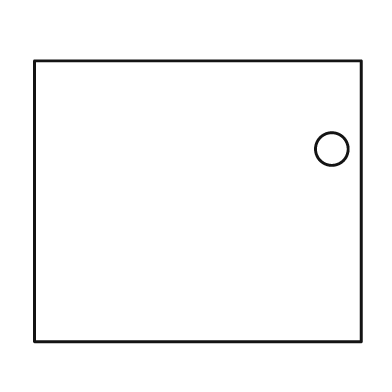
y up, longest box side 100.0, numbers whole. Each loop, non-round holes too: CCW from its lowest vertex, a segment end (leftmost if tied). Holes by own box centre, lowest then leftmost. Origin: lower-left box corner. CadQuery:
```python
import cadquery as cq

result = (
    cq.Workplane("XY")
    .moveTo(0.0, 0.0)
    .lineTo(100.0, 0.0)
    .lineTo(100.0, 86.0)
    .lineTo(0.0, 86.0)
    .close()
    .moveTo(91.0, 59.0)
    .circle(5.0)
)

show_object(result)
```